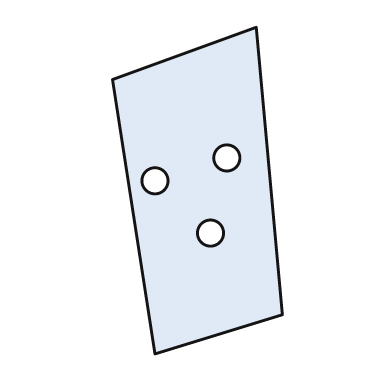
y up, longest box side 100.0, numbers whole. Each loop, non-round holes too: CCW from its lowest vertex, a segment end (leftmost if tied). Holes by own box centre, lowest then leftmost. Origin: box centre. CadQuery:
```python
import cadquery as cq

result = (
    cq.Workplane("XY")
    .moveTo(-13.0, -50.0)
    .lineTo(26.0, -38.0)
    .lineTo(18.0, 50.0)
    .lineTo(-26.0, 34.0)
    .close()
    .moveTo(4.0, -13.0)
    .circle(4.0)
    .moveTo(-13.0, 3.0)
    .circle(4.0)
    .moveTo(9.0, 10.0)
    .circle(4.0)
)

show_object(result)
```